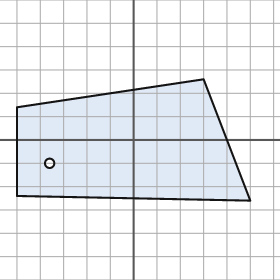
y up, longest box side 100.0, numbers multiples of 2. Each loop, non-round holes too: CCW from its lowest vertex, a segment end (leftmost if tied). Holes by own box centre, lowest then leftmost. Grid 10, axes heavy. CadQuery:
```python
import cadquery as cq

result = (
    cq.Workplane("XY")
    .moveTo(50.0, -26.0)
    .lineTo(30.0, 26.0)
    .lineTo(-50.0, 14.0)
    .lineTo(-50.0, -24.0)
    .close()
    .moveTo(-36.0, -10.0)
    .circle(2.0)
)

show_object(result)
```